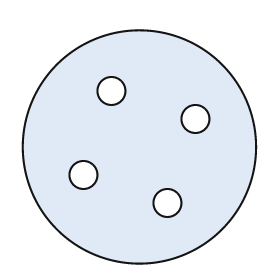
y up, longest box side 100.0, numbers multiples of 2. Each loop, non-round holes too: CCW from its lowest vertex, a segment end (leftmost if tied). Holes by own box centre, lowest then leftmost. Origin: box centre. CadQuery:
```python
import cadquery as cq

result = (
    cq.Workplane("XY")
    .moveTo(0.0, 0.0)
    .circle(50.0)
    .moveTo(12.0, -24.0)
    .circle(6.0)
    .moveTo(-24.0, -12.0)
    .circle(6.0)
    .moveTo(24.0, 12.0)
    .circle(6.0)
    .moveTo(-12.0, 24.0)
    .circle(6.0)
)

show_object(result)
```